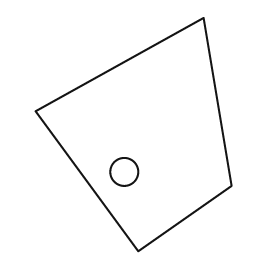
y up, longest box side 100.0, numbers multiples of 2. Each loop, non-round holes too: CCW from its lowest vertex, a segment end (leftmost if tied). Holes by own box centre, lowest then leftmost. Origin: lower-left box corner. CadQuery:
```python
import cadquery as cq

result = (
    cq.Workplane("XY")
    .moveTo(44.0, 0.0)
    .lineTo(84.0, 28.0)
    .lineTo(72.0, 100.0)
    .lineTo(0.0, 60.0)
    .close()
    .moveTo(38.0, 34.0)
    .circle(6.0)
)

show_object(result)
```